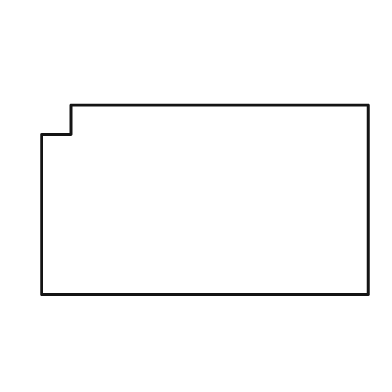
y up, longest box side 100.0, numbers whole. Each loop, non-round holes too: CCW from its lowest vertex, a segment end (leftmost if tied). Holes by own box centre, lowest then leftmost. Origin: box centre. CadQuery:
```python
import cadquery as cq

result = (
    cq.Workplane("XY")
    .moveTo(-50.0, -29.0)
    .lineTo(50.0, -29.0)
    .lineTo(50.0, 29.0)
    .lineTo(-41.0, 29.0)
    .lineTo(-41.0, 20.0)
    .lineTo(-50.0, 20.0)
    .close()
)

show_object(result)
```